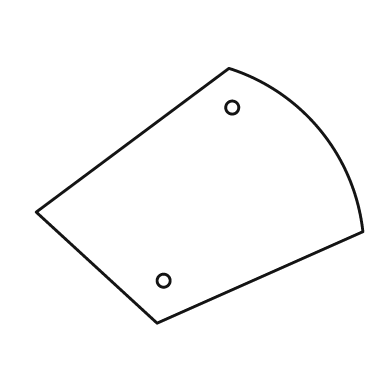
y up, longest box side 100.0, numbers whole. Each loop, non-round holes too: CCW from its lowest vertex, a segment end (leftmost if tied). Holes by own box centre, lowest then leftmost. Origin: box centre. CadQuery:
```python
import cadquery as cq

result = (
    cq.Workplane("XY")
    .moveTo(-13.0, -39.0)
    .lineTo(50.0, -11.0)
    .threePointArc((37.0, 20.0), (9.0, 39.0))
    .lineTo(-50.0, -5.0)
    .close()
    .moveTo(-11.0, -26.0)
    .circle(2.0)
    .moveTo(10.0, 27.0)
    .circle(2.0)
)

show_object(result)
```